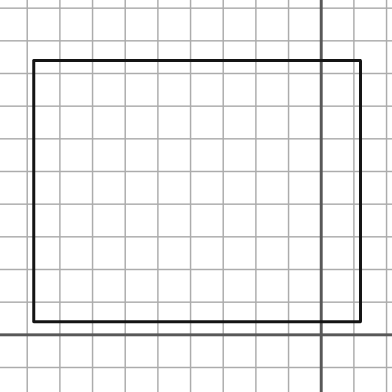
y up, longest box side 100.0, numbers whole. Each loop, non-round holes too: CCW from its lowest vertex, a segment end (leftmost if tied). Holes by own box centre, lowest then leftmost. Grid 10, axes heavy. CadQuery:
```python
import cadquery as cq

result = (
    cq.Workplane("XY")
    .moveTo(-88.0, 4.0)
    .lineTo(12.0, 4.0)
    .lineTo(12.0, 84.0)
    .lineTo(-88.0, 84.0)
    .close()
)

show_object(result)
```